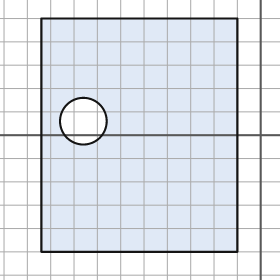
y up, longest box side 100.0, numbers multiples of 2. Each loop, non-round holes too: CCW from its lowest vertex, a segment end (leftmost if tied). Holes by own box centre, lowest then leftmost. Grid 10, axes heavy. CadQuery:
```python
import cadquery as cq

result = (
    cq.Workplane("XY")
    .moveTo(-94.0, -50.0)
    .lineTo(-10.0, -50.0)
    .lineTo(-10.0, 50.0)
    .lineTo(-94.0, 50.0)
    .close()
    .moveTo(-76.0, 6.0)
    .circle(10.0)
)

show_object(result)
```